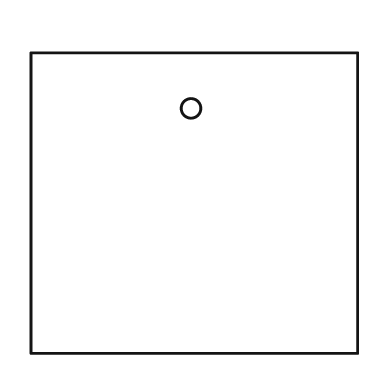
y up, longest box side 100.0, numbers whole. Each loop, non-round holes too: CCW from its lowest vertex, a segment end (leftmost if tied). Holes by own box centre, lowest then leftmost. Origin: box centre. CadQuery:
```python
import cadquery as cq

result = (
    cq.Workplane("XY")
    .moveTo(-50.0, -46.0)
    .lineTo(50.0, -46.0)
    .lineTo(50.0, 46.0)
    .lineTo(-50.0, 46.0)
    .close()
    .moveTo(-1.0, 29.0)
    .circle(3.0)
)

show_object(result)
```